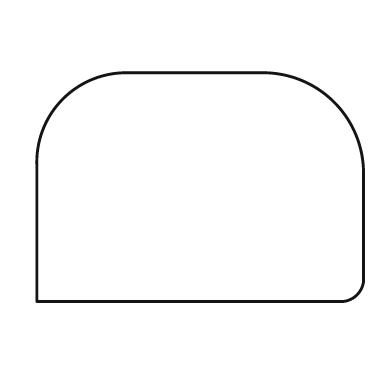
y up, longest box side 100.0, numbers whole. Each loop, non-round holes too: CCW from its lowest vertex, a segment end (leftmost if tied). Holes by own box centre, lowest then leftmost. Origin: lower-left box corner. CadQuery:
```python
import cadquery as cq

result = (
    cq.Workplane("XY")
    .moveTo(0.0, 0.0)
    .lineTo(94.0, 0.0)
    .threePointArc((98.0, 2.0), (100.0, 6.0))
    .lineTo(100.0, 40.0)
    .threePointArc((91.0, 61.0), (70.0, 70.0))
    .lineTo(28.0, 70.0)
    .threePointArc((8.0, 62.0), (0.0, 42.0))
    .close()
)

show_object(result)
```